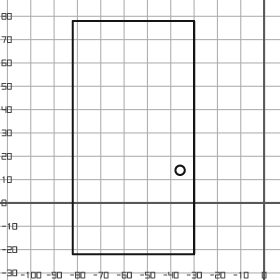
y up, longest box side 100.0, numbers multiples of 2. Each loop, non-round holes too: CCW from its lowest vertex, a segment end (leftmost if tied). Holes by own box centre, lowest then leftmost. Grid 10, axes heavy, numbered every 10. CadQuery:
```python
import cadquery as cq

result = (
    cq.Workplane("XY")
    .moveTo(-82.0, -22.0)
    .lineTo(-30.0, -22.0)
    .lineTo(-30.0, 78.0)
    .lineTo(-82.0, 78.0)
    .close()
    .moveTo(-36.0, 14.0)
    .circle(2.0)
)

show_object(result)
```